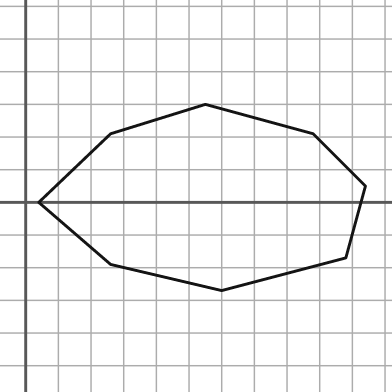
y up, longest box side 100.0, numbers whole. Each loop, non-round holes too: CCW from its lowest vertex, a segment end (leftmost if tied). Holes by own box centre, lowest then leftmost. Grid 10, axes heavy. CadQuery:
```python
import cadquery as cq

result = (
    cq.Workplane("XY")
    .moveTo(60.0, -27.0)
    .lineTo(98.0, -17.0)
    .lineTo(104.0, 5.0)
    .lineTo(88.0, 21.0)
    .lineTo(55.0, 30.0)
    .lineTo(26.0, 21.0)
    .lineTo(4.0, 0.0)
    .lineTo(26.0, -19.0)
    .close()
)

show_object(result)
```